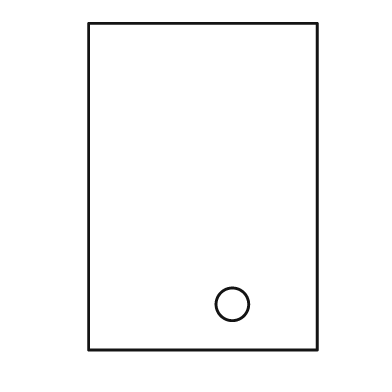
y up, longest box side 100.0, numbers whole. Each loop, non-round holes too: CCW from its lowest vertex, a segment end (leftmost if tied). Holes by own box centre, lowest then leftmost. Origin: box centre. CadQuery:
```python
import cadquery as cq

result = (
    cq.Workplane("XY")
    .moveTo(-35.0, -50.0)
    .lineTo(35.0, -50.0)
    .lineTo(35.0, 50.0)
    .lineTo(-35.0, 50.0)
    .close()
    .moveTo(9.0, -36.0)
    .circle(5.0)
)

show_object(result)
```